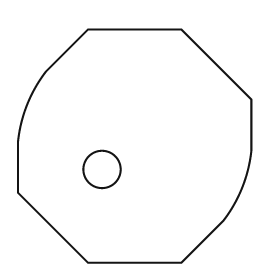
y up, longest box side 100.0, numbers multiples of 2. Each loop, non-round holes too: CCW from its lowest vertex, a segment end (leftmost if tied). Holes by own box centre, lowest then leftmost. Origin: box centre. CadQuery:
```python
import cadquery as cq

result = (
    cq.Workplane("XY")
    .moveTo(-20.0, -50.0)
    .lineTo(20.0, -50.0)
    .lineTo(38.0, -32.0)
    .threePointArc((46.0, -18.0), (50.0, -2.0))
    .lineTo(50.0, 20.0)
    .lineTo(20.0, 50.0)
    .lineTo(-20.0, 50.0)
    .lineTo(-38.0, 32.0)
    .threePointArc((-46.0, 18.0), (-50.0, 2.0))
    .lineTo(-50.0, -20.0)
    .close()
    .moveTo(-14.0, -10.0)
    .circle(8.0)
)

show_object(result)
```